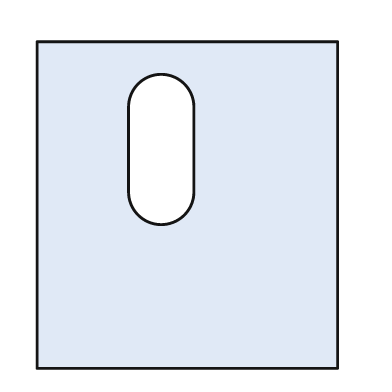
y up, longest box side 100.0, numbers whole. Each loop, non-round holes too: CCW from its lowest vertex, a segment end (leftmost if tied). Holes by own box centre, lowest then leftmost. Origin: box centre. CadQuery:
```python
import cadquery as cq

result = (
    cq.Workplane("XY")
    .moveTo(-46.0, -50.0)
    .lineTo(46.0, -50.0)
    .lineTo(46.0, 50.0)
    .lineTo(-46.0, 50.0)
    .close()
    .moveTo(-18.0, 4.0)
    .threePointArc((-8.0, -6.0), (2.0, 4.0))
    .lineTo(2.0, 30.0)
    .threePointArc((-8.0, 40.0), (-18.0, 30.0))
    .close()
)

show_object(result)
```